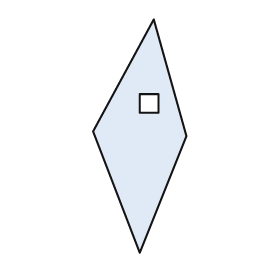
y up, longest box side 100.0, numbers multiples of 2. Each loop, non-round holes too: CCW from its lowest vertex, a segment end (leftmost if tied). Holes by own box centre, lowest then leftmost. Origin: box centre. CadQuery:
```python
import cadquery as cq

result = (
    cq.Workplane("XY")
    .moveTo(0.0, -50.0)
    .lineTo(20.0, 0.0)
    .lineTo(6.0, 50.0)
    .lineTo(-20.0, 2.0)
    .close()
    .moveTo(0.0, 10.0)
    .lineTo(8.0, 10.0)
    .lineTo(8.0, 18.0)
    .lineTo(0.0, 18.0)
    .close()
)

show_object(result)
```